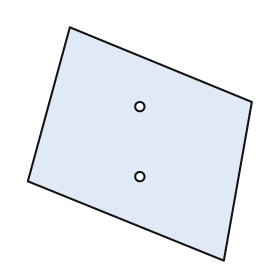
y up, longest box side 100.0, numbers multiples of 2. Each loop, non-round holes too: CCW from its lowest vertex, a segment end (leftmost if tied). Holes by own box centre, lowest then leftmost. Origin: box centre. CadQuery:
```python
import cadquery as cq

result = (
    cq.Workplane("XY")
    .moveTo(36.0, -50.0)
    .lineTo(48.0, 18.0)
    .lineTo(-30.0, 50.0)
    .lineTo(-48.0, -16.0)
    .close()
    .moveTo(0.0, -14.0)
    .circle(2.0)
    .moveTo(0.0, 16.0)
    .circle(2.0)
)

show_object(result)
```